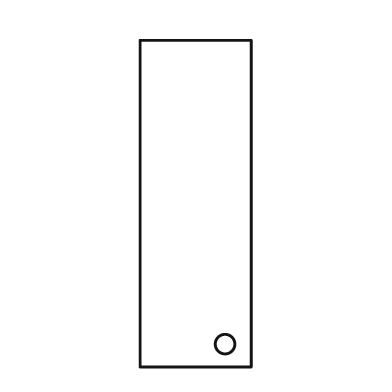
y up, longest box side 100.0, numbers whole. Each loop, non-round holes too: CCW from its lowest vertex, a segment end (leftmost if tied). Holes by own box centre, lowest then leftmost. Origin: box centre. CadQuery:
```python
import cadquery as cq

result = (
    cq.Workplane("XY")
    .moveTo(-17.0, -50.0)
    .lineTo(17.0, -50.0)
    .lineTo(17.0, 50.0)
    .lineTo(-17.0, 50.0)
    .close()
    .moveTo(9.0, -43.0)
    .circle(3.0)
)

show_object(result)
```